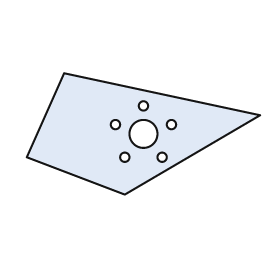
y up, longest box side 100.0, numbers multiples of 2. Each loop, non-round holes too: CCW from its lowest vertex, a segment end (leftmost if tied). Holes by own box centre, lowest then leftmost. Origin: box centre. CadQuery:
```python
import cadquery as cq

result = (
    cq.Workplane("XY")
    .moveTo(-8.0, -26.0)
    .lineTo(50.0, 8.0)
    .lineTo(-34.0, 26.0)
    .lineTo(-50.0, -10.0)
    .close()
    .moveTo(-8.0, -10.0)
    .circle(2.0)
    .moveTo(8.0, -10.0)
    .circle(2.0)
    .moveTo(0.0, 0.0)
    .circle(6.0)
    .moveTo(-12.0, 4.0)
    .circle(2.0)
    .moveTo(12.0, 4.0)
    .circle(2.0)
    .moveTo(0.0, 12.0)
    .circle(2.0)
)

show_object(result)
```